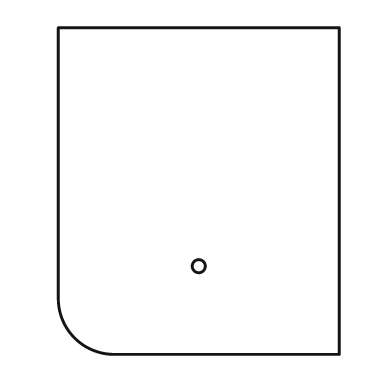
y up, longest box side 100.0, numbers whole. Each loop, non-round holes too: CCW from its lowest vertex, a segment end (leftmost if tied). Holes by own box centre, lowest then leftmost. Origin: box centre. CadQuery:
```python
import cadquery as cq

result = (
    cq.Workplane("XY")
    .moveTo(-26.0, -50.0)
    .lineTo(43.0, -50.0)
    .lineTo(43.0, 50.0)
    .lineTo(-43.0, 50.0)
    .lineTo(-43.0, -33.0)
    .threePointArc((-38.0, -45.0), (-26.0, -50.0))
    .close()
    .moveTo(0.0, -23.0)
    .circle(2.0)
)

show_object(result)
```